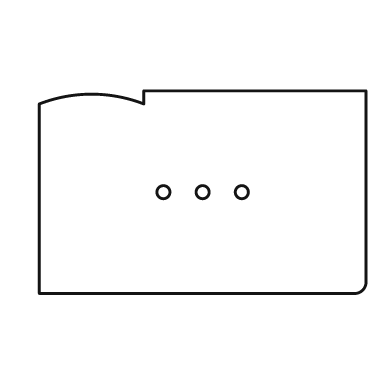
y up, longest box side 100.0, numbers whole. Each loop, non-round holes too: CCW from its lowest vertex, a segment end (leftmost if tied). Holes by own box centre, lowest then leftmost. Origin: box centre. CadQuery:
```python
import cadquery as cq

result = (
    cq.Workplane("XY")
    .moveTo(-50.0, -31.0)
    .lineTo(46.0, -31.0)
    .threePointArc((49.0, -30.0), (50.0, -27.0))
    .lineTo(50.0, 31.0)
    .lineTo(-18.0, 31.0)
    .lineTo(-18.0, 27.0)
    .threePointArc((-34.0, 30.0), (-50.0, 27.0))
    .close()
    .moveTo(-12.0, 0.0)
    .circle(2.0)
    .moveTo(0.0, 0.0)
    .circle(2.0)
    .moveTo(12.0, 0.0)
    .circle(2.0)
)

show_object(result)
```